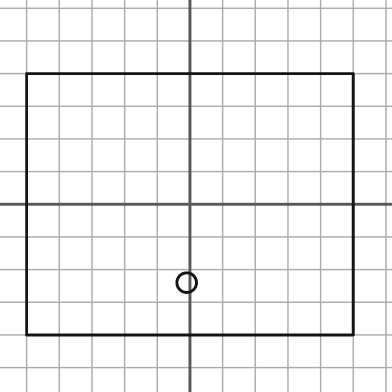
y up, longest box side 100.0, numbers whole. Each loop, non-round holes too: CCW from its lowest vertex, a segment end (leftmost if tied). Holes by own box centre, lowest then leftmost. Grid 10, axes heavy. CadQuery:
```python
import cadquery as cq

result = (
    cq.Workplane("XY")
    .moveTo(-50.0, -40.0)
    .lineTo(50.0, -40.0)
    .lineTo(50.0, 40.0)
    .lineTo(-50.0, 40.0)
    .close()
    .moveTo(-1.0, -24.0)
    .circle(3.0)
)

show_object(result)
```